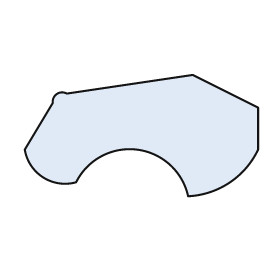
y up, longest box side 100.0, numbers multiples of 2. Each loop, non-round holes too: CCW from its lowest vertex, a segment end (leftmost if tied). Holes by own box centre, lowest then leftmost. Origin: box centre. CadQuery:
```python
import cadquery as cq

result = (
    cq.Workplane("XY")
    .moveTo(20.0, -26.0)
    .threePointArc((38.0, -20.0), (50.0, -6.0))
    .lineTo(50.0, 12.0)
    .lineTo(22.0, 26.0)
    .lineTo(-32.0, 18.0)
    .threePointArc((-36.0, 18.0), (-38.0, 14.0))
    .lineTo(-50.0, -6.0)
    .threePointArc((-42.0, -18.0), (-28.0, -20.0))
    .threePointArc((-2.0, -6.0), (20.0, -26.0))
    .close()
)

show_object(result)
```